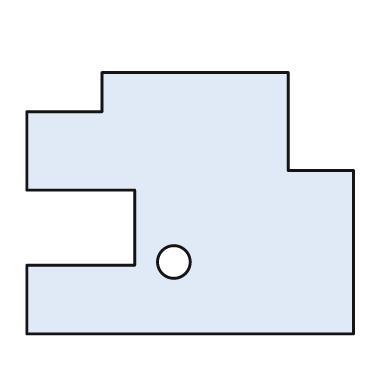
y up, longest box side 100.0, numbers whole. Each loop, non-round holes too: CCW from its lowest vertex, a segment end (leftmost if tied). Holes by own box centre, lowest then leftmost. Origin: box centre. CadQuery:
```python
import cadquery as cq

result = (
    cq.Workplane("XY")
    .moveTo(-50.0, -40.0)
    .lineTo(50.0, -40.0)
    .lineTo(50.0, 10.0)
    .lineTo(30.0, 10.0)
    .lineTo(30.0, 40.0)
    .lineTo(-27.0, 40.0)
    .lineTo(-27.0, 28.0)
    .lineTo(-50.0, 28.0)
    .lineTo(-50.0, 4.0)
    .lineTo(-17.0, 4.0)
    .lineTo(-17.0, -19.0)
    .lineTo(-50.0, -19.0)
    .close()
    .moveTo(-5.0, -18.0)
    .circle(5.0)
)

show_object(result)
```